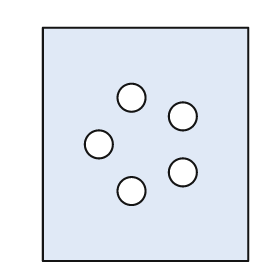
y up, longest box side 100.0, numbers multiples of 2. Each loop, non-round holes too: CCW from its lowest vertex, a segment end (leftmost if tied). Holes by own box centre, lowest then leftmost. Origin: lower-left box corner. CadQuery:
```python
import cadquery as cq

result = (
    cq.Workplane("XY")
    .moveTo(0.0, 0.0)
    .lineTo(88.0, 0.0)
    .lineTo(88.0, 100.0)
    .lineTo(0.0, 100.0)
    .close()
    .moveTo(38.0, 30.0)
    .circle(6.0)
    .moveTo(60.0, 38.0)
    .circle(6.0)
    .moveTo(24.0, 50.0)
    .circle(6.0)
    .moveTo(60.0, 62.0)
    .circle(6.0)
    .moveTo(38.0, 70.0)
    .circle(6.0)
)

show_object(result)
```